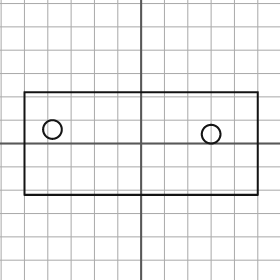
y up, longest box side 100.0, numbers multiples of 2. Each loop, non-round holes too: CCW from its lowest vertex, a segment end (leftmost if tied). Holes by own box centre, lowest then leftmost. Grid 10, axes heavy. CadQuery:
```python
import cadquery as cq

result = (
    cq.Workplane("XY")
    .moveTo(-50.0, -22.0)
    .lineTo(50.0, -22.0)
    .lineTo(50.0, 22.0)
    .lineTo(-50.0, 22.0)
    .close()
    .moveTo(30.0, 4.0)
    .circle(4.0)
    .moveTo(-38.0, 6.0)
    .circle(4.0)
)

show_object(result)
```